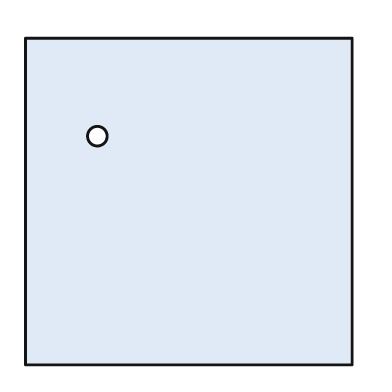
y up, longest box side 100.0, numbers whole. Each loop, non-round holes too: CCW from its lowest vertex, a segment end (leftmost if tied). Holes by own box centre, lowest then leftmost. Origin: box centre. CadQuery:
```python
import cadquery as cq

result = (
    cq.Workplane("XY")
    .moveTo(-50.0, -50.0)
    .lineTo(50.0, -50.0)
    .lineTo(50.0, 50.0)
    .lineTo(-50.0, 50.0)
    .close()
    .moveTo(-28.0, 20.0)
    .circle(3.0)
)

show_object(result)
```